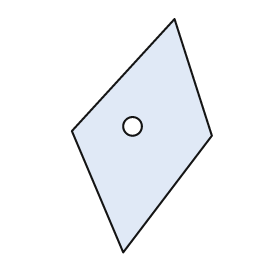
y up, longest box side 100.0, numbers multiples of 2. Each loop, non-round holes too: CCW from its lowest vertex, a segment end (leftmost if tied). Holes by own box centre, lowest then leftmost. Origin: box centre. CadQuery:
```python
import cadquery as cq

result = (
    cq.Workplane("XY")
    .moveTo(-8.0, -50.0)
    .lineTo(30.0, 0.0)
    .lineTo(14.0, 50.0)
    .lineTo(-30.0, 2.0)
    .close()
    .moveTo(-4.0, 4.0)
    .circle(4.0)
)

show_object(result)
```